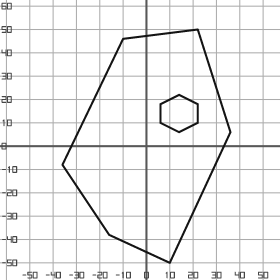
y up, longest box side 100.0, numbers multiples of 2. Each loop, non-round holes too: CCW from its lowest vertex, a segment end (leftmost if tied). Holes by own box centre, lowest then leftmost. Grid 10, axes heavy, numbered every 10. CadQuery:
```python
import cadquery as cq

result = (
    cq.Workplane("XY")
    .moveTo(10.0, -50.0)
    .lineTo(36.0, 6.0)
    .lineTo(22.0, 50.0)
    .lineTo(-10.0, 46.0)
    .lineTo(-36.0, -8.0)
    .lineTo(-16.0, -38.0)
    .close()
    .moveTo(14.0, 6.0)
    .lineTo(22.0, 10.0)
    .lineTo(22.0, 18.0)
    .lineTo(14.0, 22.0)
    .lineTo(6.0, 18.0)
    .lineTo(6.0, 10.0)
    .close()
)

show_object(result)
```